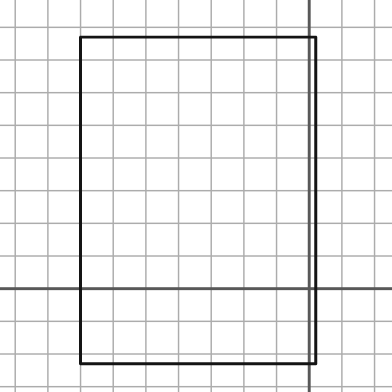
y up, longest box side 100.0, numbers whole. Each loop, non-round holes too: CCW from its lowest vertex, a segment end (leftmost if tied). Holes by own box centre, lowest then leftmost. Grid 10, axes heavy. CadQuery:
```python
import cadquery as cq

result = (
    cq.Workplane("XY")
    .moveTo(-70.0, -23.0)
    .lineTo(2.0, -23.0)
    .lineTo(2.0, 77.0)
    .lineTo(-70.0, 77.0)
    .close()
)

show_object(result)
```